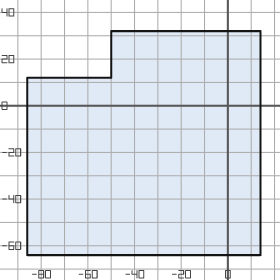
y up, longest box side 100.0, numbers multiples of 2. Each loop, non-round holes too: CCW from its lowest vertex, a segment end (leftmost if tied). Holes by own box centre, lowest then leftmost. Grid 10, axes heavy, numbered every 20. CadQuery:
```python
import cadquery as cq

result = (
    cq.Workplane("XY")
    .moveTo(-86.0, -64.0)
    .lineTo(14.0, -64.0)
    .lineTo(14.0, 32.0)
    .lineTo(-50.0, 32.0)
    .lineTo(-50.0, 12.0)
    .lineTo(-86.0, 12.0)
    .close()
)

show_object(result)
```